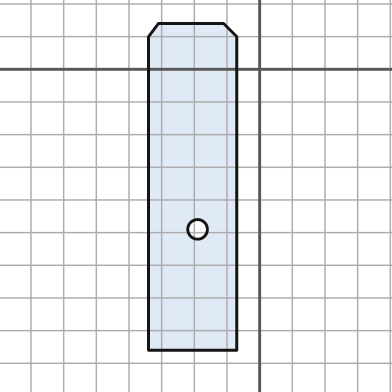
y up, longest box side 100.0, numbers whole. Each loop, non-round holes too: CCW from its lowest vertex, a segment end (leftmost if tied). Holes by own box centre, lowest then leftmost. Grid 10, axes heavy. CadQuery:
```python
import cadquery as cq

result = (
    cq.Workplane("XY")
    .moveTo(-34.0, -86.0)
    .lineTo(-7.0, -86.0)
    .lineTo(-7.0, 10.0)
    .lineTo(-11.0, 14.0)
    .lineTo(-31.0, 14.0)
    .lineTo(-34.0, 10.0)
    .close()
    .moveTo(-19.0, -49.0)
    .circle(3.0)
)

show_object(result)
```